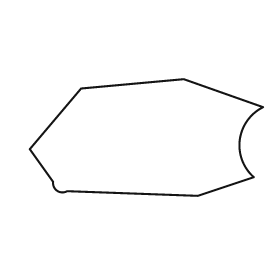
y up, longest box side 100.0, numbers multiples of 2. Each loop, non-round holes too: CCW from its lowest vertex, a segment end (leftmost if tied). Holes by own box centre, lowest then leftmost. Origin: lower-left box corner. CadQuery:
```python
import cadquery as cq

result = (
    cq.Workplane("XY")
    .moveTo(72.0, 0.0)
    .lineTo(96.0, 8.0)
    .threePointArc((90.0, 24.0), (100.0, 38.0))
    .lineTo(66.0, 50.0)
    .lineTo(22.0, 46.0)
    .lineTo(0.0, 20.0)
    .lineTo(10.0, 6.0)
    .threePointArc((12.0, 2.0), (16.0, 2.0))
    .close()
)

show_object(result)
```